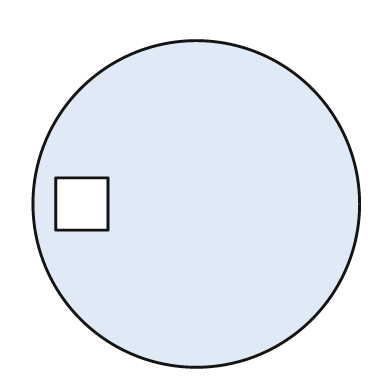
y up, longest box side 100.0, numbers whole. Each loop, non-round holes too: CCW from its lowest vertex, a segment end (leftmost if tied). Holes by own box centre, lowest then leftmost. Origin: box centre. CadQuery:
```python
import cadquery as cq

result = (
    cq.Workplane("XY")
    .moveTo(0.0, 0.0)
    .circle(50.0)
    .moveTo(-43.0, -8.0)
    .lineTo(-27.0, -8.0)
    .lineTo(-27.0, 8.0)
    .lineTo(-43.0, 8.0)
    .close()
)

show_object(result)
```